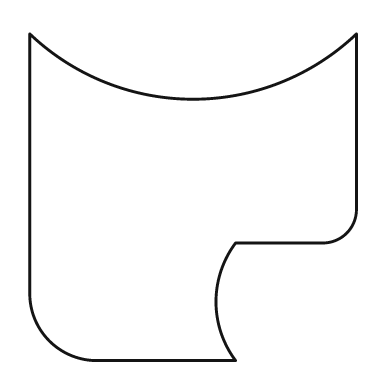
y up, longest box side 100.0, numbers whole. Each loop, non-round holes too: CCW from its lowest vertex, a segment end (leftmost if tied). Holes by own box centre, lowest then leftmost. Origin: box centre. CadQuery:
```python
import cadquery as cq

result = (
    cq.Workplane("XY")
    .moveTo(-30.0, -50.0)
    .lineTo(13.0, -50.0)
    .threePointArc((7.0, -32.0), (13.0, -14.0))
    .lineTo(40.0, -14.0)
    .threePointArc((47.0, -11.0), (50.0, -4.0))
    .lineTo(50.0, 50.0)
    .threePointArc((0.0, 30.0), (-50.0, 50.0))
    .lineTo(-50.0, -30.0)
    .threePointArc((-44.0, -44.0), (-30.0, -50.0))
    .close()
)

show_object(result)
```